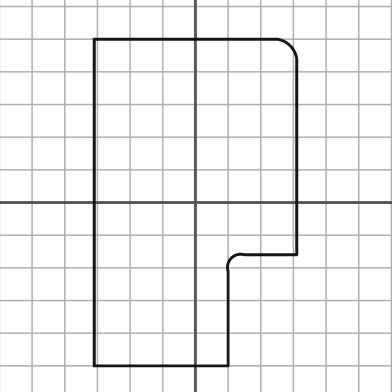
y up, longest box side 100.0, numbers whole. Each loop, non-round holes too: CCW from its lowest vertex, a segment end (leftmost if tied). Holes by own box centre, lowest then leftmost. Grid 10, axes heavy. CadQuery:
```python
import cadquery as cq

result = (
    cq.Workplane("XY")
    .moveTo(-31.0, -50.0)
    .lineTo(10.0, -50.0)
    .lineTo(10.0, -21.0)
    .threePointArc((11.0, -17.0), (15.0, -16.0))
    .lineTo(31.0, -16.0)
    .lineTo(31.0, 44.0)
    .threePointArc((29.0, 48.0), (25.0, 50.0))
    .lineTo(-31.0, 50.0)
    .close()
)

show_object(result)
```